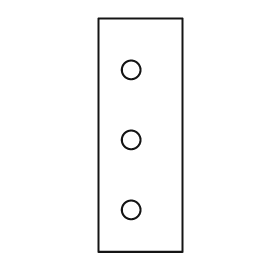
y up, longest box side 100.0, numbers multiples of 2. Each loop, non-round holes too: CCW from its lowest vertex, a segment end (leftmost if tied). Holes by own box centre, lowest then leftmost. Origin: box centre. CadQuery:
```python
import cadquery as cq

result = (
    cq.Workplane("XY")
    .moveTo(-18.0, -50.0)
    .lineTo(18.0, -50.0)
    .lineTo(18.0, 50.0)
    .lineTo(-18.0, 50.0)
    .close()
    .moveTo(-4.0, -32.0)
    .circle(4.0)
    .moveTo(-4.0, -2.0)
    .circle(4.0)
    .moveTo(-4.0, 28.0)
    .circle(4.0)
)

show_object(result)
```